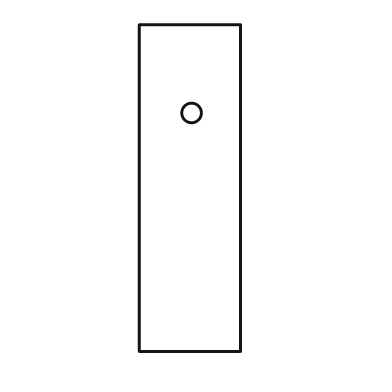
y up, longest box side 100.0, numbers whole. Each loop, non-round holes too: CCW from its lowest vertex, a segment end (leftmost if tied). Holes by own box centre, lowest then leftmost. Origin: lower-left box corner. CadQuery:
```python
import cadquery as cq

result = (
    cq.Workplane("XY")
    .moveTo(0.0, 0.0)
    .lineTo(31.0, 0.0)
    .lineTo(31.0, 100.0)
    .lineTo(0.0, 100.0)
    .close()
    .moveTo(16.0, 73.0)
    .circle(3.0)
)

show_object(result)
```